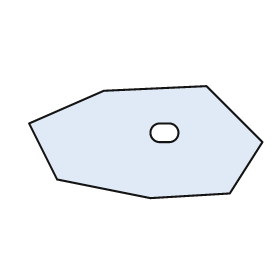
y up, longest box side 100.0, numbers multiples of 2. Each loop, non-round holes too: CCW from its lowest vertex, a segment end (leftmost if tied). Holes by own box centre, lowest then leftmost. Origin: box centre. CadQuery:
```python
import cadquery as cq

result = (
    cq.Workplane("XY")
    .moveTo(2.0, -24.0)
    .lineTo(36.0, -22.0)
    .lineTo(50.0, 0.0)
    .lineTo(26.0, 24.0)
    .lineTo(-18.0, 22.0)
    .lineTo(-50.0, 8.0)
    .lineTo(-38.0, -16.0)
    .close()
    .moveTo(6.0, 0.0)
    .lineTo(10.0, 0.0)
    .threePointArc((14.0, 4.0), (10.0, 8.0))
    .lineTo(6.0, 8.0)
    .threePointArc((2.0, 4.0), (6.0, 0.0))
    .close()
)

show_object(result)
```